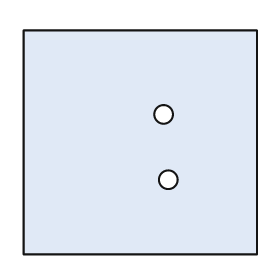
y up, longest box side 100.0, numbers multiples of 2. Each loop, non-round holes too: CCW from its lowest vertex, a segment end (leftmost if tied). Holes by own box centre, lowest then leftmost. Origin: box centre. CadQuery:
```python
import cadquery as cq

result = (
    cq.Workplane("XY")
    .moveTo(-50.0, -48.0)
    .lineTo(50.0, -48.0)
    .lineTo(50.0, 48.0)
    .lineTo(-50.0, 48.0)
    .close()
    .moveTo(12.0, -16.0)
    .circle(4.0)
    .moveTo(10.0, 12.0)
    .circle(4.0)
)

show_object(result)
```